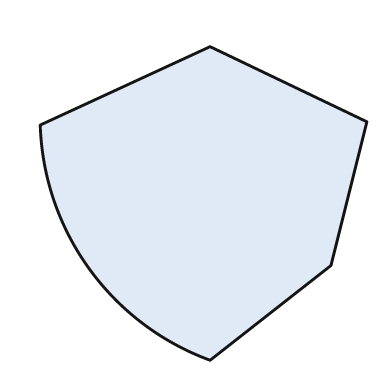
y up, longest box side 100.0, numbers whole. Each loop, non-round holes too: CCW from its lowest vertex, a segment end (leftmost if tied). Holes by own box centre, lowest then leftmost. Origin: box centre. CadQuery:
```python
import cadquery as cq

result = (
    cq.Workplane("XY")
    .moveTo(2.0, -48.0)
    .lineTo(39.0, -19.0)
    .lineTo(50.0, 25.0)
    .lineTo(2.0, 48.0)
    .lineTo(-50.0, 24.0)
    .threePointArc((-35.0, -20.0), (2.0, -48.0))
    .close()
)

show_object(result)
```